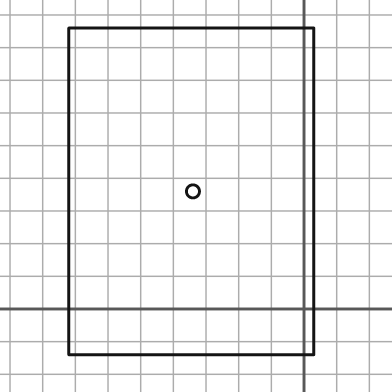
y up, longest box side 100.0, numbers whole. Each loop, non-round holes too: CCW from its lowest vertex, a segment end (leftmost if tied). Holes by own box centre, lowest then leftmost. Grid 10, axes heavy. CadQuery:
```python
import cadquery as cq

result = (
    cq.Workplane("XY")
    .moveTo(-72.0, -14.0)
    .lineTo(3.0, -14.0)
    .lineTo(3.0, 86.0)
    .lineTo(-72.0, 86.0)
    .close()
    .moveTo(-34.0, 36.0)
    .circle(2.0)
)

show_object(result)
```